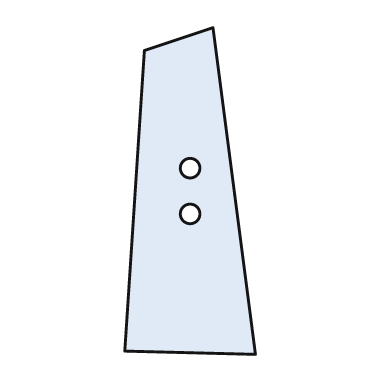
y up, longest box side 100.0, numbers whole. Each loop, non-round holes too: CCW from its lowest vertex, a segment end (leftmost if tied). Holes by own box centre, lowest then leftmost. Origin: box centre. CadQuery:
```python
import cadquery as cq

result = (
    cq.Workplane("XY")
    .moveTo(20.0, -50.0)
    .lineTo(7.0, 50.0)
    .lineTo(-14.0, 43.0)
    .lineTo(-20.0, -49.0)
    .close()
    .moveTo(0.0, -7.0)
    .circle(3.0)
    .moveTo(0.0, 7.0)
    .circle(3.0)
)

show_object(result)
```